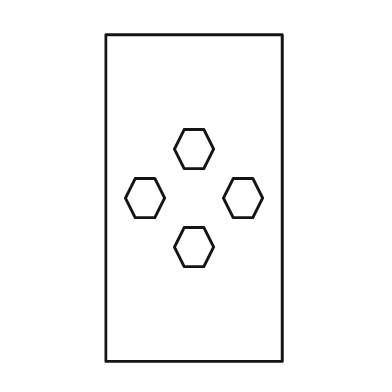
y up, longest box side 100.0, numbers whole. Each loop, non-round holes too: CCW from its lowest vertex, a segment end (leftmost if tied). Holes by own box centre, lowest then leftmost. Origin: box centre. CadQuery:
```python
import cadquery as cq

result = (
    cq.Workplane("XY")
    .moveTo(-27.0, -50.0)
    .lineTo(27.0, -50.0)
    .lineTo(27.0, 50.0)
    .lineTo(-27.0, 50.0)
    .close()
    .moveTo(-3.0, -21.0)
    .lineTo(3.0, -21.0)
    .lineTo(6.0, -15.0)
    .lineTo(3.0, -9.0)
    .lineTo(-3.0, -9.0)
    .lineTo(-6.0, -15.0)
    .close()
    .moveTo(-18.0, -6.0)
    .lineTo(-12.0, -6.0)
    .lineTo(-9.0, 0.0)
    .lineTo(-12.0, 6.0)
    .lineTo(-18.0, 6.0)
    .lineTo(-21.0, 0.0)
    .close()
    .moveTo(12.0, -6.0)
    .lineTo(18.0, -6.0)
    .lineTo(21.0, 0.0)
    .lineTo(18.0, 6.0)
    .lineTo(12.0, 6.0)
    .lineTo(9.0, 0.0)
    .close()
    .moveTo(-3.0, 9.0)
    .lineTo(3.0, 9.0)
    .lineTo(6.0, 15.0)
    .lineTo(3.0, 21.0)
    .lineTo(-3.0, 21.0)
    .lineTo(-6.0, 15.0)
    .close()
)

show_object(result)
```